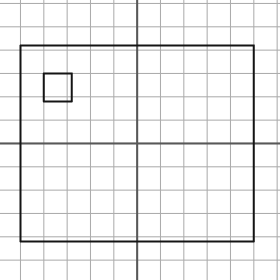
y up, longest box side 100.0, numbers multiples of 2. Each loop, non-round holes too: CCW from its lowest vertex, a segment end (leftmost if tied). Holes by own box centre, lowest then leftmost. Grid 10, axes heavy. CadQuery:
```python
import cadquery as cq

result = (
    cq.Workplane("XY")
    .moveTo(-50.0, -42.0)
    .lineTo(50.0, -42.0)
    .lineTo(50.0, 42.0)
    .lineTo(-50.0, 42.0)
    .close()
    .moveTo(-40.0, 18.0)
    .lineTo(-28.0, 18.0)
    .lineTo(-28.0, 30.0)
    .lineTo(-40.0, 30.0)
    .close()
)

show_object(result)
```